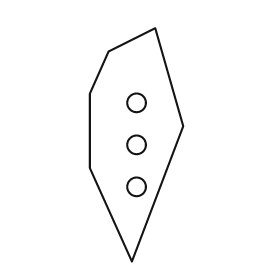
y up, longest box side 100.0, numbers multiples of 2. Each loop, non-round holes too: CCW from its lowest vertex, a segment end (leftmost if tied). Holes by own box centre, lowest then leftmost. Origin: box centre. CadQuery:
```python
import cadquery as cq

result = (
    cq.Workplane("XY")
    .moveTo(-2.0, -50.0)
    .lineTo(20.0, 8.0)
    .lineTo(8.0, 50.0)
    .lineTo(-12.0, 40.0)
    .lineTo(-20.0, 22.0)
    .lineTo(-20.0, -10.0)
    .close()
    .moveTo(0.0, -18.0)
    .circle(4.0)
    .moveTo(0.0, 0.0)
    .circle(4.0)
    .moveTo(0.0, 18.0)
    .circle(4.0)
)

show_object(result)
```